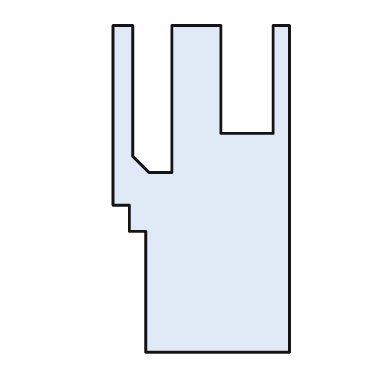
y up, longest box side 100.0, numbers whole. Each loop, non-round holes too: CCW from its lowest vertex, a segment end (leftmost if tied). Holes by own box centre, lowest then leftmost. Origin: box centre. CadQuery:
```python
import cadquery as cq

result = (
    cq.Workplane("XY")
    .moveTo(-17.0, -50.0)
    .lineTo(27.0, -50.0)
    .lineTo(27.0, 50.0)
    .lineTo(22.0, 50.0)
    .lineTo(22.0, 17.0)
    .lineTo(6.0, 17.0)
    .lineTo(6.0, 50.0)
    .lineTo(-9.0, 50.0)
    .lineTo(-9.0, 5.0)
    .lineTo(-16.0, 5.0)
    .lineTo(-21.0, 10.0)
    .lineTo(-21.0, 50.0)
    .lineTo(-27.0, 50.0)
    .lineTo(-27.0, -5.0)
    .lineTo(-22.0, -5.0)
    .lineTo(-22.0, -13.0)
    .lineTo(-17.0, -13.0)
    .close()
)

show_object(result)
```